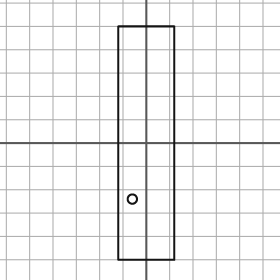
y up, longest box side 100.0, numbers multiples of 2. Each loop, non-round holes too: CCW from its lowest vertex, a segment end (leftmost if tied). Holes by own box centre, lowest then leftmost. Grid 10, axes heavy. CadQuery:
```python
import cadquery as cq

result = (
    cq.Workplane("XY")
    .moveTo(-12.0, -50.0)
    .lineTo(12.0, -50.0)
    .lineTo(12.0, 50.0)
    .lineTo(-12.0, 50.0)
    .close()
    .moveTo(-6.0, -24.0)
    .circle(2.0)
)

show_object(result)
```